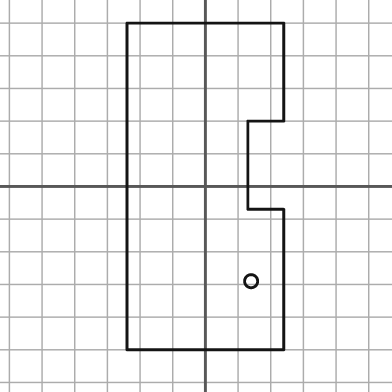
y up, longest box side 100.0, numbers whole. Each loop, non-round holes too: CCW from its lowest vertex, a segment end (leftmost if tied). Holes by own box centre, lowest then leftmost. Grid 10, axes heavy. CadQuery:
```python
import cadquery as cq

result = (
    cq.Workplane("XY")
    .moveTo(-24.0, -50.0)
    .lineTo(24.0, -50.0)
    .lineTo(24.0, -7.0)
    .lineTo(13.0, -7.0)
    .lineTo(13.0, 20.0)
    .lineTo(24.0, 20.0)
    .lineTo(24.0, 50.0)
    .lineTo(-24.0, 50.0)
    .close()
    .moveTo(14.0, -29.0)
    .circle(2.0)
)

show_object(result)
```